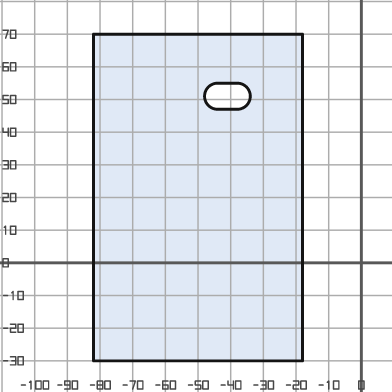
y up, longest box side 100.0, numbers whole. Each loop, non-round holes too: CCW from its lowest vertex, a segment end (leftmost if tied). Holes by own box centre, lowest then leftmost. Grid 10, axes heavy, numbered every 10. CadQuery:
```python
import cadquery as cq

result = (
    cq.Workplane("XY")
    .moveTo(-82.0, -30.0)
    .lineTo(-18.0, -30.0)
    .lineTo(-18.0, 70.0)
    .lineTo(-82.0, 70.0)
    .close()
    .moveTo(-44.0, 47.0)
    .lineTo(-38.0, 47.0)
    .threePointArc((-34.0, 51.0), (-38.0, 55.0))
    .lineTo(-44.0, 55.0)
    .threePointArc((-48.0, 51.0), (-44.0, 47.0))
    .close()
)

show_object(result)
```